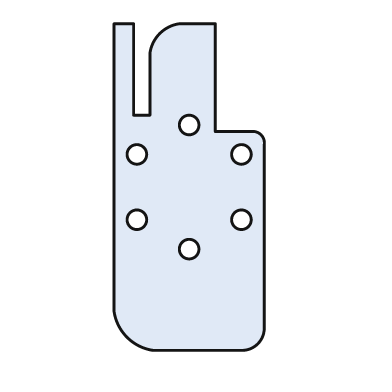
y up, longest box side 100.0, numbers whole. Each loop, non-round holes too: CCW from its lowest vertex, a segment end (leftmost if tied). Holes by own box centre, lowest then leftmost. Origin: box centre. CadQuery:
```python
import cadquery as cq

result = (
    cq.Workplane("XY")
    .moveTo(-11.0, -50.0)
    .lineTo(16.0, -50.0)
    .threePointArc((21.0, -48.0), (23.0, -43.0))
    .lineTo(23.0, 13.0)
    .threePointArc((22.0, 16.0), (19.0, 17.0))
    .lineTo(8.0, 17.0)
    .lineTo(8.0, 50.0)
    .lineTo(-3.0, 50.0)
    .threePointArc((-9.0, 47.0), (-12.0, 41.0))
    .lineTo(-12.0, 22.0)
    .lineTo(-17.0, 22.0)
    .lineTo(-17.0, 50.0)
    .lineTo(-23.0, 50.0)
    .lineTo(-23.0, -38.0)
    .threePointArc((-19.0, -46.0), (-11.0, -50.0))
    .close()
    .moveTo(0.0, -19.0)
    .circle(3.0)
    .moveTo(-16.0, -10.0)
    .circle(3.0)
    .moveTo(16.0, -10.0)
    .circle(3.0)
    .moveTo(-16.0, 10.0)
    .circle(3.0)
    .moveTo(16.0, 10.0)
    .circle(3.0)
    .moveTo(0.0, 19.0)
    .circle(3.0)
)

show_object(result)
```